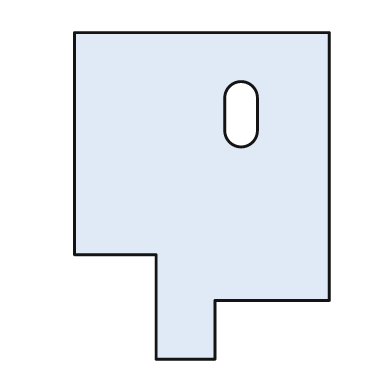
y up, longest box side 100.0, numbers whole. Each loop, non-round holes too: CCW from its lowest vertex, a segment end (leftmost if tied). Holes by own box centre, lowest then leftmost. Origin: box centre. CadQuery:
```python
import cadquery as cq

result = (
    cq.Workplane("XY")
    .moveTo(-14.0, -50.0)
    .lineTo(4.0, -50.0)
    .lineTo(4.0, -32.0)
    .lineTo(39.0, -32.0)
    .lineTo(39.0, 50.0)
    .lineTo(-39.0, 50.0)
    .lineTo(-39.0, -18.0)
    .lineTo(-14.0, -18.0)
    .close()
    .moveTo(7.0, 20.0)
    .threePointArc((12.0, 15.0), (17.0, 20.0))
    .lineTo(17.0, 30.0)
    .threePointArc((12.0, 35.0), (7.0, 30.0))
    .close()
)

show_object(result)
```